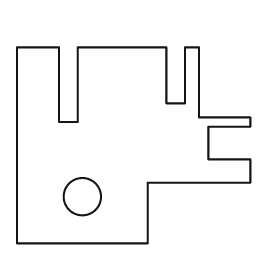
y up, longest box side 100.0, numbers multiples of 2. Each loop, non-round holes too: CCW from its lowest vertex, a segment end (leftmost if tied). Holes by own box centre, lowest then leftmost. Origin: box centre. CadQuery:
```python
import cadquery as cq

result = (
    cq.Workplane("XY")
    .moveTo(-50.0, -42.0)
    .lineTo(6.0, -42.0)
    .lineTo(6.0, -16.0)
    .lineTo(50.0, -16.0)
    .lineTo(50.0, -6.0)
    .lineTo(32.0, -6.0)
    .lineTo(32.0, 8.0)
    .lineTo(50.0, 8.0)
    .lineTo(50.0, 12.0)
    .lineTo(28.0, 12.0)
    .lineTo(28.0, 42.0)
    .lineTo(22.0, 42.0)
    .lineTo(22.0, 18.0)
    .lineTo(14.0, 18.0)
    .lineTo(14.0, 42.0)
    .lineTo(-24.0, 42.0)
    .lineTo(-24.0, 10.0)
    .lineTo(-32.0, 10.0)
    .lineTo(-32.0, 42.0)
    .lineTo(-50.0, 42.0)
    .close()
    .moveTo(-22.0, -22.0)
    .circle(8.0)
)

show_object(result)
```